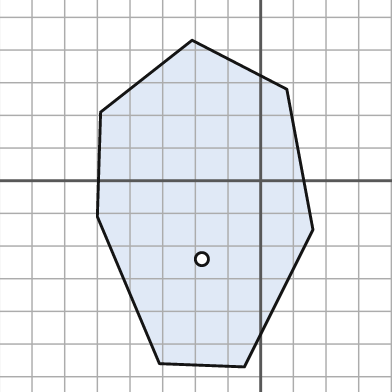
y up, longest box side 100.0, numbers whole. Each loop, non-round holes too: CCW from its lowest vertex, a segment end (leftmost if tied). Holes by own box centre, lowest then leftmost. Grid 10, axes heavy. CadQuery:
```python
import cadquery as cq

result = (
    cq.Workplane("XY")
    .moveTo(-5.0, -57.0)
    .lineTo(16.0, -15.0)
    .lineTo(8.0, 28.0)
    .lineTo(-21.0, 43.0)
    .lineTo(-49.0, 21.0)
    .lineTo(-50.0, -11.0)
    .lineTo(-31.0, -56.0)
    .close()
    .moveTo(-18.0, -24.0)
    .circle(2.0)
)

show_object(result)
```